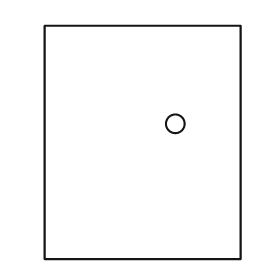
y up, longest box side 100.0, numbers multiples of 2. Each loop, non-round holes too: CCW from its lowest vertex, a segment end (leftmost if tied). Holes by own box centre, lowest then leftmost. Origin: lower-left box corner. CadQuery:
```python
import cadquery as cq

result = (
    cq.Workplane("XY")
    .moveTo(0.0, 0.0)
    .lineTo(84.0, 0.0)
    .lineTo(84.0, 100.0)
    .lineTo(0.0, 100.0)
    .close()
    .moveTo(56.0, 58.0)
    .circle(4.0)
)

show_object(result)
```